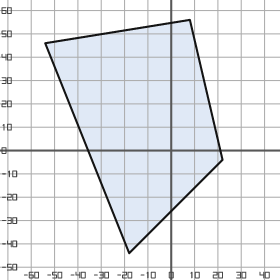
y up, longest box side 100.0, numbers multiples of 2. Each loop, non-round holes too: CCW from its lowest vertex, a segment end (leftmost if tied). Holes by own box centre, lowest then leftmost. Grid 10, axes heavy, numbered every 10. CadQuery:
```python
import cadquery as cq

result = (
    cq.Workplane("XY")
    .moveTo(-18.0, -44.0)
    .lineTo(22.0, -4.0)
    .lineTo(8.0, 56.0)
    .lineTo(-54.0, 46.0)
    .close()
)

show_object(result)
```